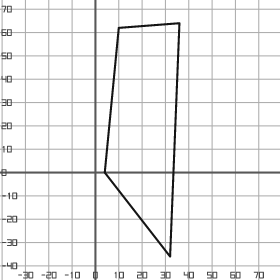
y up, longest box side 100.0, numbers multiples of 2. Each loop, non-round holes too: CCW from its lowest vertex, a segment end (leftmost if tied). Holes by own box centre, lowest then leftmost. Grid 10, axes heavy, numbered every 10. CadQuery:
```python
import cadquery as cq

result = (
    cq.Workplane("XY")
    .moveTo(32.0, -36.0)
    .lineTo(36.0, 64.0)
    .lineTo(10.0, 62.0)
    .lineTo(4.0, 0.0)
    .close()
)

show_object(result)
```